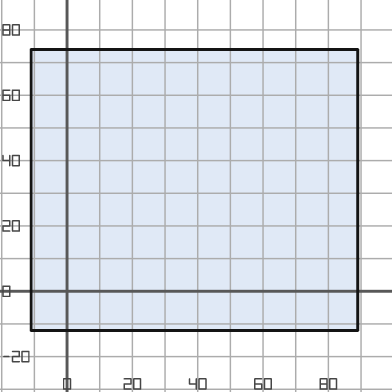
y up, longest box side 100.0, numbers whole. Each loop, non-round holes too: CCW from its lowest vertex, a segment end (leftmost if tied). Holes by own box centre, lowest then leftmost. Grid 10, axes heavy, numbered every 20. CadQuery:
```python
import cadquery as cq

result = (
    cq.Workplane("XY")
    .moveTo(-11.0, -12.0)
    .lineTo(89.0, -12.0)
    .lineTo(89.0, 74.0)
    .lineTo(-11.0, 74.0)
    .close()
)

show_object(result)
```